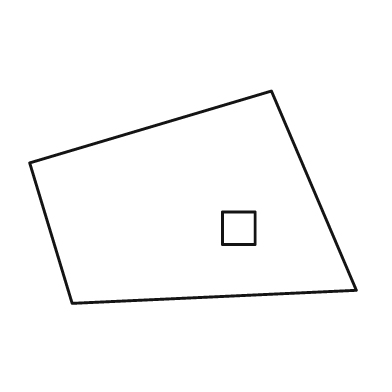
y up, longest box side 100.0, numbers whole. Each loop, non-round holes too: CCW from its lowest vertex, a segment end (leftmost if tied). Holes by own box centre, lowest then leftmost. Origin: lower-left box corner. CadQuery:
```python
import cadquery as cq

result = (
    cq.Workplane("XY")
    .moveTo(13.0, 0.0)
    .lineTo(100.0, 4.0)
    .lineTo(74.0, 65.0)
    .lineTo(0.0, 43.0)
    .close()
    .moveTo(59.0, 18.0)
    .lineTo(69.0, 18.0)
    .lineTo(69.0, 28.0)
    .lineTo(59.0, 28.0)
    .close()
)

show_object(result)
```